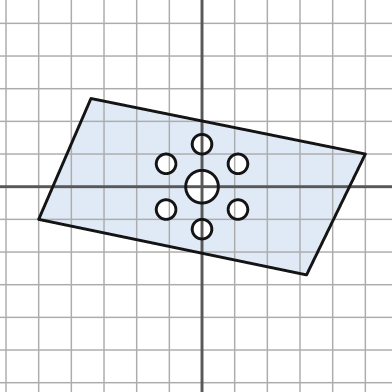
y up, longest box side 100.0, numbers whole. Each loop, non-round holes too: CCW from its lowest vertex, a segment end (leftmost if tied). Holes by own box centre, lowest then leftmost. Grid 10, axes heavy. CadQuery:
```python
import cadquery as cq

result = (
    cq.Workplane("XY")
    .moveTo(32.0, -27.0)
    .lineTo(50.0, 10.0)
    .lineTo(-34.0, 27.0)
    .lineTo(-50.0, -10.0)
    .close()
    .moveTo(0.0, -13.0)
    .circle(3.0)
    .moveTo(-11.0, -7.0)
    .circle(3.0)
    .moveTo(11.0, -7.0)
    .circle(3.0)
    .moveTo(0.0, 0.0)
    .circle(5.0)
    .moveTo(-11.0, 7.0)
    .circle(3.0)
    .moveTo(11.0, 7.0)
    .circle(3.0)
    .moveTo(0.0, 13.0)
    .circle(3.0)
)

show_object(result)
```